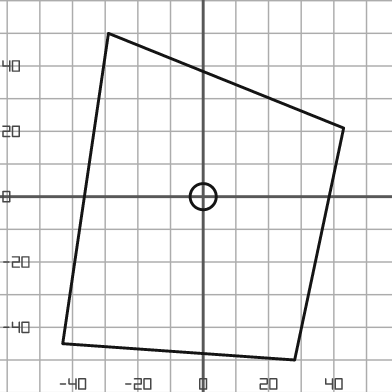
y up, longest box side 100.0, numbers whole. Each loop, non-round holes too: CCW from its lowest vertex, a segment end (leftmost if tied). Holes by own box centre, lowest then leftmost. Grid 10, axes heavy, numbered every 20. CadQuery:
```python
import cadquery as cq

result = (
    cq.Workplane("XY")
    .moveTo(28.0, -50.0)
    .lineTo(43.0, 21.0)
    .lineTo(-29.0, 50.0)
    .lineTo(-43.0, -45.0)
    .close()
    .moveTo(0.0, 0.0)
    .circle(4.0)
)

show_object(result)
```